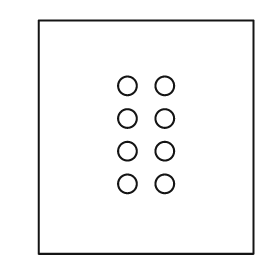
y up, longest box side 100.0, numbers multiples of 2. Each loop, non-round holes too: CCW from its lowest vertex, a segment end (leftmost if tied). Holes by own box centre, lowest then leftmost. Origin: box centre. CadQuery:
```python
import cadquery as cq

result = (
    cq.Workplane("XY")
    .moveTo(-46.0, -50.0)
    .lineTo(46.0, -50.0)
    .lineTo(46.0, 50.0)
    .lineTo(-46.0, 50.0)
    .close()
    .moveTo(-8.0, -20.0)
    .circle(4.0)
    .moveTo(8.0, -20.0)
    .circle(4.0)
    .moveTo(-8.0, -6.0)
    .circle(4.0)
    .moveTo(8.0, -6.0)
    .circle(4.0)
    .moveTo(-8.0, 8.0)
    .circle(4.0)
    .moveTo(8.0, 8.0)
    .circle(4.0)
    .moveTo(-8.0, 22.0)
    .circle(4.0)
    .moveTo(8.0, 22.0)
    .circle(4.0)
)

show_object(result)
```